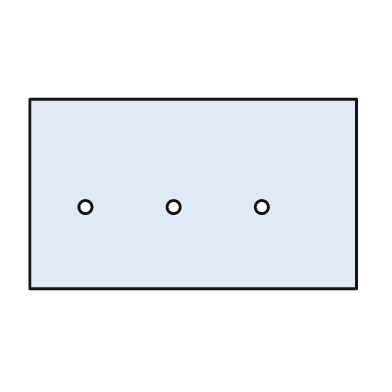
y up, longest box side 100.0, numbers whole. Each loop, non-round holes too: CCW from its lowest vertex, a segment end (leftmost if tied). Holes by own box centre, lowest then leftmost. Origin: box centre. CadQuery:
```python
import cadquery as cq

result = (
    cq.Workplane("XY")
    .moveTo(-50.0, -29.0)
    .lineTo(50.0, -29.0)
    .lineTo(50.0, 29.0)
    .lineTo(-50.0, 29.0)
    .close()
    .moveTo(-33.0, -4.0)
    .circle(2.0)
    .moveTo(-6.0, -4.0)
    .circle(2.0)
    .moveTo(21.0, -4.0)
    .circle(2.0)
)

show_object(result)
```